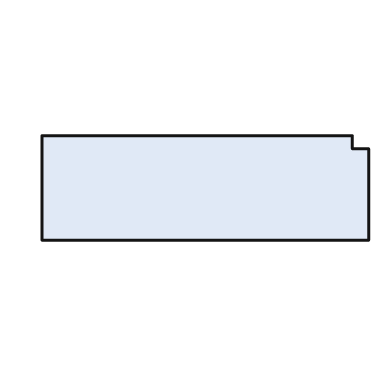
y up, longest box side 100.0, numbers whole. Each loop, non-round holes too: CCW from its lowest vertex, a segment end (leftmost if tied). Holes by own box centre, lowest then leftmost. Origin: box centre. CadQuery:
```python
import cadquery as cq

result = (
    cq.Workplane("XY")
    .moveTo(-50.0, -16.0)
    .lineTo(50.0, -16.0)
    .lineTo(50.0, 12.0)
    .lineTo(45.0, 12.0)
    .lineTo(45.0, 16.0)
    .lineTo(-50.0, 16.0)
    .close()
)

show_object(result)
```